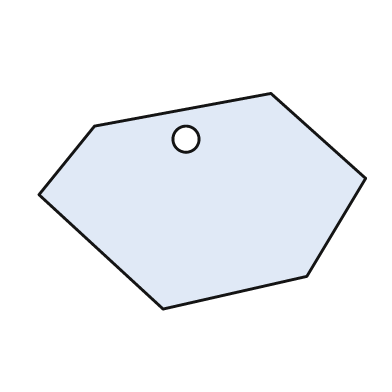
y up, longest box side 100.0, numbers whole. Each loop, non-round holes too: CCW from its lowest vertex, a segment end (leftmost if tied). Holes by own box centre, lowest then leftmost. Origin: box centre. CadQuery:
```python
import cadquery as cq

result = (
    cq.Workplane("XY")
    .moveTo(-12.0, -33.0)
    .lineTo(32.0, -23.0)
    .lineTo(50.0, 7.0)
    .lineTo(21.0, 33.0)
    .lineTo(-33.0, 23.0)
    .lineTo(-50.0, 2.0)
    .close()
    .moveTo(-5.0, 19.0)
    .circle(4.0)
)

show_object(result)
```